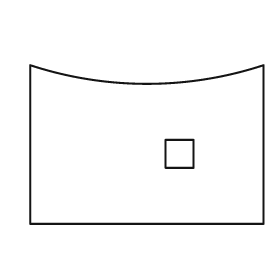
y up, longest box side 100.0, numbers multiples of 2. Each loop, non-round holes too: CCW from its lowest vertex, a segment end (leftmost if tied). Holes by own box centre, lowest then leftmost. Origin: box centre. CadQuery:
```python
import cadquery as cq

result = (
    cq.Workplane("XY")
    .moveTo(-50.0, -34.0)
    .lineTo(50.0, -34.0)
    .lineTo(50.0, 34.0)
    .threePointArc((0.0, 26.0), (-50.0, 34.0))
    .close()
    .moveTo(8.0, -10.0)
    .lineTo(20.0, -10.0)
    .lineTo(20.0, 2.0)
    .lineTo(8.0, 2.0)
    .close()
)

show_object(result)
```